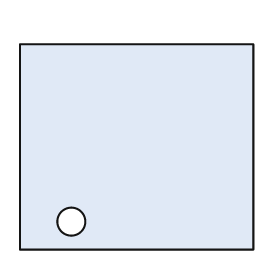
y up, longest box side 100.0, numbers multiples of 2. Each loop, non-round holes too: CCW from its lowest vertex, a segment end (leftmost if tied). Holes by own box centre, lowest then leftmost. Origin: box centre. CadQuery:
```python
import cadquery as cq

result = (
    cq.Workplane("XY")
    .moveTo(-50.0, -44.0)
    .lineTo(50.0, -44.0)
    .lineTo(50.0, 44.0)
    .lineTo(-50.0, 44.0)
    .close()
    .moveTo(-28.0, -32.0)
    .circle(6.0)
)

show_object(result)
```